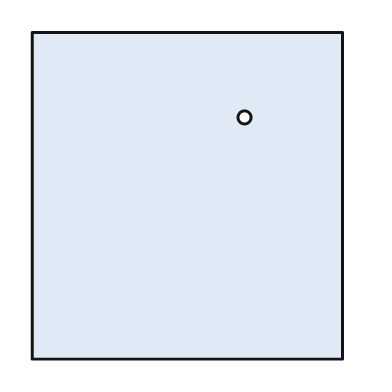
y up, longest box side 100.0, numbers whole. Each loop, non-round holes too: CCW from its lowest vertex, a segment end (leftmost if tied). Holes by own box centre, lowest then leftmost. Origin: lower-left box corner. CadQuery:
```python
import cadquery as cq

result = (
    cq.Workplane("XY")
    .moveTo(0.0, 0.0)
    .lineTo(95.0, 0.0)
    .lineTo(95.0, 100.0)
    .lineTo(0.0, 100.0)
    .close()
    .moveTo(65.0, 74.0)
    .circle(2.0)
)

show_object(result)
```